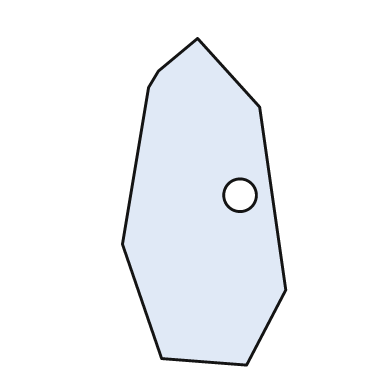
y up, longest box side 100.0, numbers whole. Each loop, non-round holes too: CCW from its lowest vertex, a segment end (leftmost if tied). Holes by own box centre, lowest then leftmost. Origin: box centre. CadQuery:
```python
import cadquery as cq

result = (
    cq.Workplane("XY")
    .moveTo(13.0, -50.0)
    .lineTo(25.0, -27.0)
    .lineTo(17.0, 29.0)
    .lineTo(-2.0, 50.0)
    .lineTo(-14.0, 40.0)
    .lineTo(-17.0, 35.0)
    .lineTo(-25.0, -13.0)
    .lineTo(-13.0, -48.0)
    .close()
    .moveTo(11.0, 2.0)
    .circle(5.0)
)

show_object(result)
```